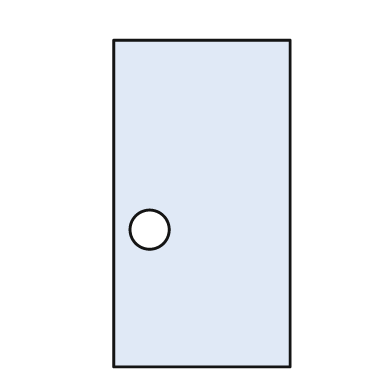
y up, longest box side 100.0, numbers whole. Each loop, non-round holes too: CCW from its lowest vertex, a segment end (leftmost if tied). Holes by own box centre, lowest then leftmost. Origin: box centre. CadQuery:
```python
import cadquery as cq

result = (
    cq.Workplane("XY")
    .moveTo(-27.0, -50.0)
    .lineTo(27.0, -50.0)
    .lineTo(27.0, 50.0)
    .lineTo(-27.0, 50.0)
    .close()
    .moveTo(-16.0, -8.0)
    .circle(6.0)
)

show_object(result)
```